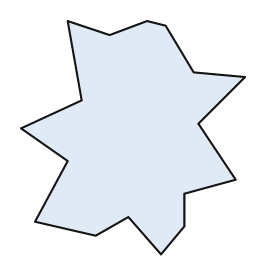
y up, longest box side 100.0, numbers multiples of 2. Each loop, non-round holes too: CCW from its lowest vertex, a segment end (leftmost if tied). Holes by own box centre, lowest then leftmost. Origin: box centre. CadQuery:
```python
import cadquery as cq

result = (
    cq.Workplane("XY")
    .moveTo(12.0, -50.0)
    .lineTo(22.0, -38.0)
    .lineTo(22.0, -24.0)
    .lineTo(44.0, -18.0)
    .lineTo(28.0, 6.0)
    .lineTo(48.0, 26.0)
    .lineTo(26.0, 28.0)
    .lineTo(14.0, 48.0)
    .lineTo(6.0, 50.0)
    .lineTo(-10.0, 44.0)
    .lineTo(-28.0, 50.0)
    .lineTo(-22.0, 16.0)
    .lineTo(-48.0, 4.0)
    .lineTo(-28.0, -10.0)
    .lineTo(-42.0, -36.0)
    .lineTo(-16.0, -42.0)
    .lineTo(-2.0, -34.0)
    .close()
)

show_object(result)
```